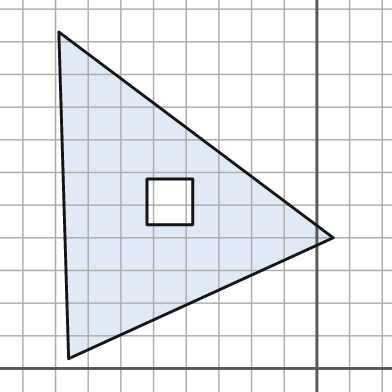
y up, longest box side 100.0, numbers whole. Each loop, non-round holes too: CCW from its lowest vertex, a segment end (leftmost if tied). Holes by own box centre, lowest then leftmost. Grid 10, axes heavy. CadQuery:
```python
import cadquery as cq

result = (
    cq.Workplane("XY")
    .moveTo(-76.0, 3.0)
    .lineTo(5.0, 40.0)
    .lineTo(-79.0, 103.0)
    .close()
    .moveTo(-52.0, 44.0)
    .lineTo(-38.0, 44.0)
    .lineTo(-38.0, 58.0)
    .lineTo(-52.0, 58.0)
    .close()
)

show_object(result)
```